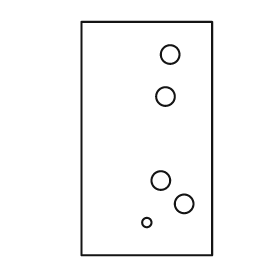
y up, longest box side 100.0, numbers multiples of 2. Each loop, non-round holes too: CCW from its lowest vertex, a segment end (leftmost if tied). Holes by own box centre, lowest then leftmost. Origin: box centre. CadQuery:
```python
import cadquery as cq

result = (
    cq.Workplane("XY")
    .moveTo(-28.0, -50.0)
    .lineTo(28.0, -50.0)
    .lineTo(28.0, 50.0)
    .lineTo(-28.0, 50.0)
    .close()
    .moveTo(0.0, -36.0)
    .circle(2.0)
    .moveTo(16.0, -28.0)
    .circle(4.0)
    .moveTo(6.0, -18.0)
    .circle(4.0)
    .moveTo(8.0, 18.0)
    .circle(4.0)
    .moveTo(10.0, 36.0)
    .circle(4.0)
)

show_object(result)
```